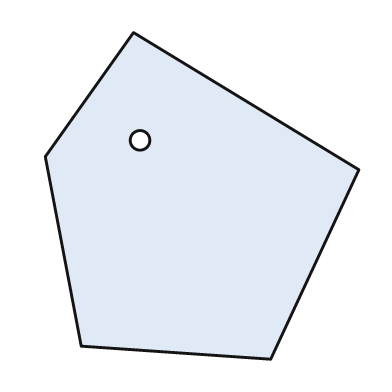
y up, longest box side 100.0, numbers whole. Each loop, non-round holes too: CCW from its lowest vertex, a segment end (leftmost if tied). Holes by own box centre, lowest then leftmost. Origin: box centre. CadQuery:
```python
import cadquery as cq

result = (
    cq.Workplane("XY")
    .moveTo(21.0, -50.0)
    .lineTo(48.0, 8.0)
    .lineTo(-21.0, 50.0)
    .lineTo(-48.0, 12.0)
    .lineTo(-37.0, -46.0)
    .close()
    .moveTo(-19.0, 17.0)
    .circle(3.0)
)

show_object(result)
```